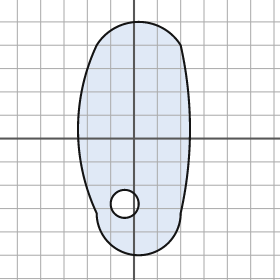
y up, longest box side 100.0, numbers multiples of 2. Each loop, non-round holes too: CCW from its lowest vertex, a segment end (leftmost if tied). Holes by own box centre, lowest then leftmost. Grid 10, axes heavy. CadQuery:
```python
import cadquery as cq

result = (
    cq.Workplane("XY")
    .moveTo(-16.0, -32.0)
    .threePointArc((2.0, -50.0), (20.0, -32.0))
    .threePointArc((24.0, 4.0), (20.0, 40.0))
    .threePointArc((2.0, 50.0), (-16.0, 40.0))
    .threePointArc((-24.0, 4.0), (-16.0, -32.0))
    .close()
    .moveTo(-4.0, -28.0)
    .circle(6.0)
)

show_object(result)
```